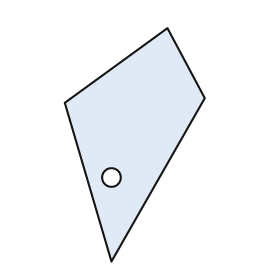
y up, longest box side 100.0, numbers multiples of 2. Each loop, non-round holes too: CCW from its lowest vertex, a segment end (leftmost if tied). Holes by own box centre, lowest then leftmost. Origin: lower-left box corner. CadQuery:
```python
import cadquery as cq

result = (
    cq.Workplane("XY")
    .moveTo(20.0, 0.0)
    .lineTo(60.0, 70.0)
    .lineTo(44.0, 100.0)
    .lineTo(0.0, 68.0)
    .close()
    .moveTo(20.0, 36.0)
    .circle(4.0)
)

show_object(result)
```